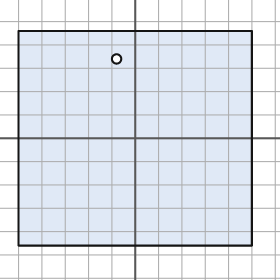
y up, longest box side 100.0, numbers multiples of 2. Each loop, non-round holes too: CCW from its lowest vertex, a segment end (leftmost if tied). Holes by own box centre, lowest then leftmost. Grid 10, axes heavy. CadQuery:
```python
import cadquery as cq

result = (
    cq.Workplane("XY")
    .moveTo(-50.0, -46.0)
    .lineTo(50.0, -46.0)
    .lineTo(50.0, 46.0)
    .lineTo(-50.0, 46.0)
    .close()
    .moveTo(-8.0, 34.0)
    .circle(2.0)
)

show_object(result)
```